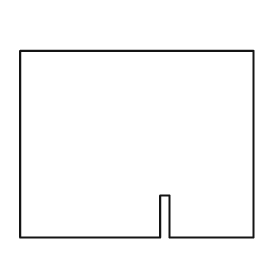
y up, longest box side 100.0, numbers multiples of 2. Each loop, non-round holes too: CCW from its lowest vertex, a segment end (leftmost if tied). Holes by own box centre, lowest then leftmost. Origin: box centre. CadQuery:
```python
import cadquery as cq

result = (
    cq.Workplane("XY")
    .moveTo(-50.0, -40.0)
    .lineTo(10.0, -40.0)
    .lineTo(10.0, -22.0)
    .lineTo(14.0, -22.0)
    .lineTo(14.0, -40.0)
    .lineTo(50.0, -40.0)
    .lineTo(50.0, 40.0)
    .lineTo(-50.0, 40.0)
    .close()
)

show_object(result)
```